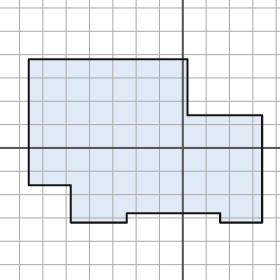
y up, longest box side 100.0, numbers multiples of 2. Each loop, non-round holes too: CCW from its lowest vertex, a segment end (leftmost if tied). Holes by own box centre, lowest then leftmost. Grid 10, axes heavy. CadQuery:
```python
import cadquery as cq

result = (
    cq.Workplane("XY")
    .moveTo(-48.0, -32.0)
    .lineTo(-24.0, -32.0)
    .lineTo(-24.0, -28.0)
    .lineTo(16.0, -28.0)
    .lineTo(16.0, -32.0)
    .lineTo(34.0, -32.0)
    .lineTo(34.0, 14.0)
    .lineTo(2.0, 14.0)
    .lineTo(2.0, 38.0)
    .lineTo(-66.0, 38.0)
    .lineTo(-66.0, -16.0)
    .lineTo(-48.0, -16.0)
    .close()
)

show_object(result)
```